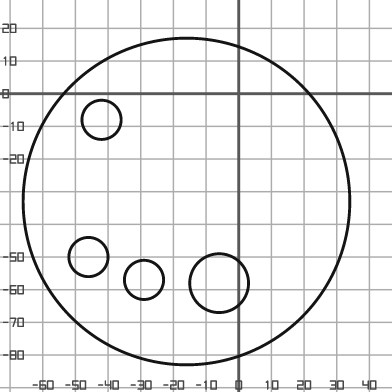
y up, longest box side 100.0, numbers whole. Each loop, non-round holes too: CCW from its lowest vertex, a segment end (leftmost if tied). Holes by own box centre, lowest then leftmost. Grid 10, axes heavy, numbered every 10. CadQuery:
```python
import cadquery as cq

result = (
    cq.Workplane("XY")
    .moveTo(-16.0, -33.0)
    .circle(50.0)
    .moveTo(-6.0, -58.0)
    .circle(9.0)
    .moveTo(-29.0, -57.0)
    .circle(6.0)
    .moveTo(-46.0, -50.0)
    .circle(6.0)
    .moveTo(-42.0, -8.0)
    .circle(6.0)
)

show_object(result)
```